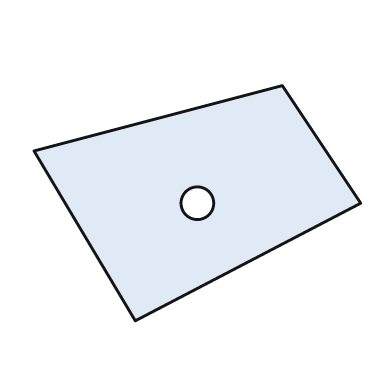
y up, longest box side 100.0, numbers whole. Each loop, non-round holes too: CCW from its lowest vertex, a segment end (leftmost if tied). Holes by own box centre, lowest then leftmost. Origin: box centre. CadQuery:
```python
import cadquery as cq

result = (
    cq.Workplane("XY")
    .moveTo(-19.0, -36.0)
    .lineTo(50.0, 0.0)
    .lineTo(26.0, 36.0)
    .lineTo(-50.0, 16.0)
    .close()
    .moveTo(0.0, 0.0)
    .circle(5.0)
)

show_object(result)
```